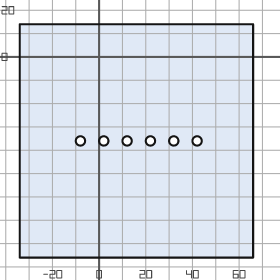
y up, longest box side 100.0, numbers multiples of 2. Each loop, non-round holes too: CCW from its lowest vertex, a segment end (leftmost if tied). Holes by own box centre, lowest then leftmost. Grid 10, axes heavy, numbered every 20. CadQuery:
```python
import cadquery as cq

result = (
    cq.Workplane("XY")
    .moveTo(-34.0, -86.0)
    .lineTo(66.0, -86.0)
    .lineTo(66.0, 14.0)
    .lineTo(-34.0, 14.0)
    .close()
    .moveTo(-8.0, -36.0)
    .circle(2.0)
    .moveTo(2.0, -36.0)
    .circle(2.0)
    .moveTo(12.0, -36.0)
    .circle(2.0)
    .moveTo(22.0, -36.0)
    .circle(2.0)
    .moveTo(32.0, -36.0)
    .circle(2.0)
    .moveTo(42.0, -36.0)
    .circle(2.0)
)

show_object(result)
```